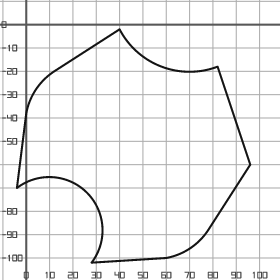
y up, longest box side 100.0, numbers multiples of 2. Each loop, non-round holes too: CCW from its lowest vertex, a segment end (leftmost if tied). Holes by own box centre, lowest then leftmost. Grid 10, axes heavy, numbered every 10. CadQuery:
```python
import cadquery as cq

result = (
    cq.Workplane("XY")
    .moveTo(28.0, -102.0)
    .lineTo(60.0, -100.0)
    .threePointArc((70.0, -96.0), (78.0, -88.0))
    .lineTo(96.0, -60.0)
    .lineTo(82.0, -18.0)
    .threePointArc((58.0, -18.0), (40.0, -2.0))
    .lineTo(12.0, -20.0)
    .threePointArc((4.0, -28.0), (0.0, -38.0))
    .lineTo(-4.0, -70.0)
    .threePointArc((26.0, -72.0), (28.0, -102.0))
    .close()
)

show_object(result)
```